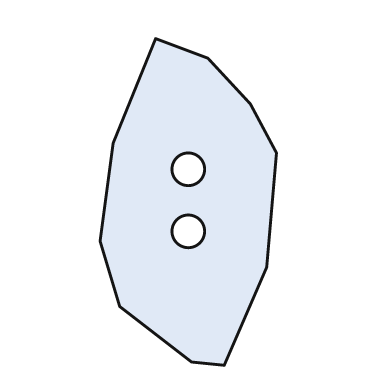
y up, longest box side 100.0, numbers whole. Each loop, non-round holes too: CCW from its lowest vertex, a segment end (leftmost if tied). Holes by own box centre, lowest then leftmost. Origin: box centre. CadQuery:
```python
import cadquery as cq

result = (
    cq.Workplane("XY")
    .moveTo(11.0, -50.0)
    .lineTo(24.0, -20.0)
    .lineTo(27.0, 15.0)
    .lineTo(19.0, 30.0)
    .lineTo(6.0, 44.0)
    .lineTo(-10.0, 50.0)
    .lineTo(-23.0, 18.0)
    .lineTo(-27.0, -12.0)
    .lineTo(-21.0, -32.0)
    .lineTo(1.0, -49.0)
    .close()
    .moveTo(0.0, -9.0)
    .circle(5.0)
    .moveTo(0.0, 10.0)
    .circle(5.0)
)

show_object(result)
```